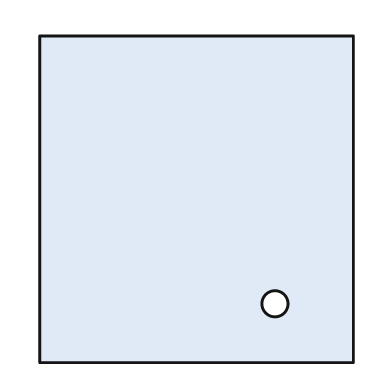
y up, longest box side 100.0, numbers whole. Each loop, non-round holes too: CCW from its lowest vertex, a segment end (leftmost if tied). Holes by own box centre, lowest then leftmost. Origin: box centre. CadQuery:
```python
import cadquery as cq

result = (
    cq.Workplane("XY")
    .moveTo(-48.0, -50.0)
    .lineTo(48.0, -50.0)
    .lineTo(48.0, 50.0)
    .lineTo(-48.0, 50.0)
    .close()
    .moveTo(24.0, -32.0)
    .circle(4.0)
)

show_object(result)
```